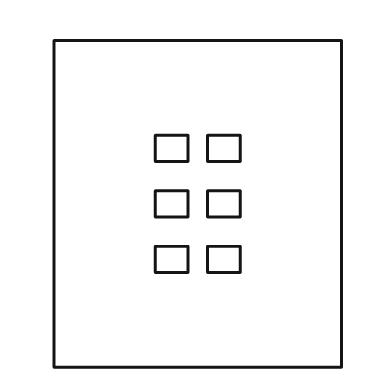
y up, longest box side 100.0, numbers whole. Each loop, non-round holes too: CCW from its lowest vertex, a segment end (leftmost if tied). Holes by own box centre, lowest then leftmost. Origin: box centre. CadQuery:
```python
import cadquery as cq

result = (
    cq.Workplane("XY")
    .moveTo(-44.0, -50.0)
    .lineTo(44.0, -50.0)
    .lineTo(44.0, 50.0)
    .lineTo(-44.0, 50.0)
    .close()
    .moveTo(-13.0, -21.0)
    .lineTo(-3.0, -21.0)
    .lineTo(-3.0, -13.0)
    .lineTo(-13.0, -13.0)
    .close()
    .moveTo(3.0, -21.0)
    .lineTo(13.0, -21.0)
    .lineTo(13.0, -13.0)
    .lineTo(3.0, -13.0)
    .close()
    .moveTo(-13.0, -4.0)
    .lineTo(-3.0, -4.0)
    .lineTo(-3.0, 4.0)
    .lineTo(-13.0, 4.0)
    .close()
    .moveTo(3.0, -4.0)
    .lineTo(13.0, -4.0)
    .lineTo(13.0, 4.0)
    .lineTo(3.0, 4.0)
    .close()
    .moveTo(-13.0, 13.0)
    .lineTo(-3.0, 13.0)
    .lineTo(-3.0, 21.0)
    .lineTo(-13.0, 21.0)
    .close()
    .moveTo(3.0, 13.0)
    .lineTo(13.0, 13.0)
    .lineTo(13.0, 21.0)
    .lineTo(3.0, 21.0)
    .close()
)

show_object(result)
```